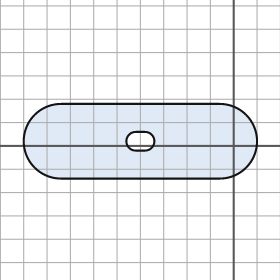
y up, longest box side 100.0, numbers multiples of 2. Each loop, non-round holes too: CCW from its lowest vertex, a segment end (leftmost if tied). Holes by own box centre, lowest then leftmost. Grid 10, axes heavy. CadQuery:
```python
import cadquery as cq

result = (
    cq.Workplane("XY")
    .moveTo(-74.0, -14.0)
    .lineTo(-6.0, -14.0)
    .threePointArc((10.0, 2.0), (-6.0, 18.0))
    .lineTo(-74.0, 18.0)
    .threePointArc((-90.0, 2.0), (-74.0, -14.0))
    .close()
    .moveTo(-42.0, -2.0)
    .lineTo(-38.0, -2.0)
    .threePointArc((-34.0, 2.0), (-38.0, 6.0))
    .lineTo(-42.0, 6.0)
    .threePointArc((-46.0, 2.0), (-42.0, -2.0))
    .close()
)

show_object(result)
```